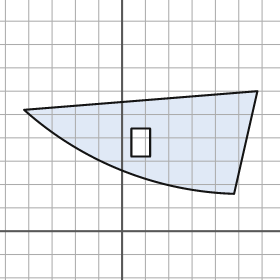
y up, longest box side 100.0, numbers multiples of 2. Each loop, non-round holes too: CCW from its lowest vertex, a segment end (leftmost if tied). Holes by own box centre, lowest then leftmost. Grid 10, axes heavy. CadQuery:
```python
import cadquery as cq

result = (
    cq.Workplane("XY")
    .moveTo(48.0, 16.0)
    .lineTo(58.0, 60.0)
    .lineTo(-42.0, 52.0)
    .threePointArc((0.0, 26.0), (48.0, 16.0))
    .close()
    .moveTo(4.0, 32.0)
    .lineTo(12.0, 32.0)
    .lineTo(12.0, 44.0)
    .lineTo(4.0, 44.0)
    .close()
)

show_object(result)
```